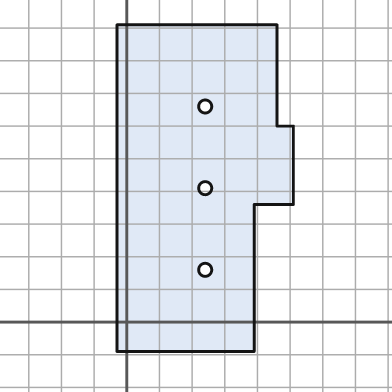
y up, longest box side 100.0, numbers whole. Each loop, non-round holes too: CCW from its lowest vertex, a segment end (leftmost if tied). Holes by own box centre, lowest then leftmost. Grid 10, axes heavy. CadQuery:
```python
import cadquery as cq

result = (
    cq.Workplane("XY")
    .moveTo(-3.0, -9.0)
    .lineTo(39.0, -9.0)
    .lineTo(39.0, 36.0)
    .lineTo(51.0, 36.0)
    .lineTo(51.0, 60.0)
    .lineTo(46.0, 60.0)
    .lineTo(46.0, 91.0)
    .lineTo(-3.0, 91.0)
    .close()
    .moveTo(24.0, 16.0)
    .circle(2.0)
    .moveTo(24.0, 41.0)
    .circle(2.0)
    .moveTo(24.0, 66.0)
    .circle(2.0)
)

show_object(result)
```